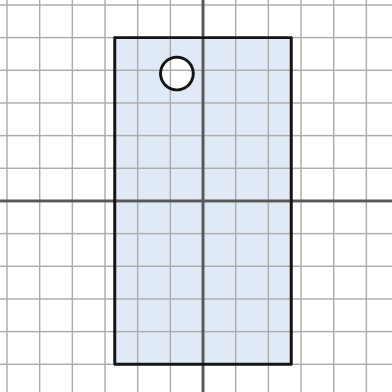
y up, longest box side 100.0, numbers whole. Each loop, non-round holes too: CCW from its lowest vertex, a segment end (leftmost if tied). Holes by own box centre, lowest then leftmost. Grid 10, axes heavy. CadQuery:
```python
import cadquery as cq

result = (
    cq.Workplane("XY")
    .moveTo(-27.0, -50.0)
    .lineTo(27.0, -50.0)
    .lineTo(27.0, 50.0)
    .lineTo(-27.0, 50.0)
    .close()
    .moveTo(-8.0, 39.0)
    .circle(5.0)
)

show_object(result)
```